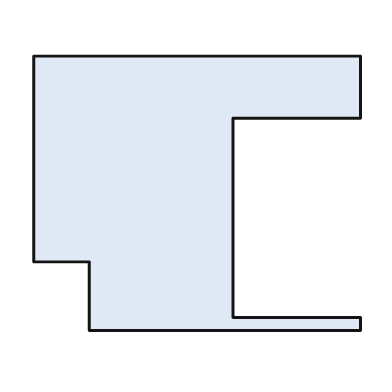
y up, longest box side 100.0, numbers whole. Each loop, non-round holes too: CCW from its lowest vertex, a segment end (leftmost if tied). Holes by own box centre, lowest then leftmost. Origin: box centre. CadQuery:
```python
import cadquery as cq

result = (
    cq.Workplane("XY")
    .moveTo(-33.0, -42.0)
    .lineTo(50.0, -42.0)
    .lineTo(50.0, -38.0)
    .lineTo(11.0, -38.0)
    .lineTo(11.0, 23.0)
    .lineTo(50.0, 23.0)
    .lineTo(50.0, 42.0)
    .lineTo(-50.0, 42.0)
    .lineTo(-50.0, -21.0)
    .lineTo(-33.0, -21.0)
    .close()
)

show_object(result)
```